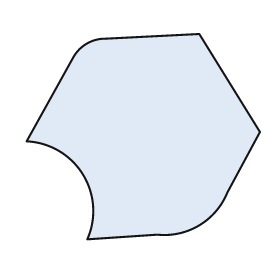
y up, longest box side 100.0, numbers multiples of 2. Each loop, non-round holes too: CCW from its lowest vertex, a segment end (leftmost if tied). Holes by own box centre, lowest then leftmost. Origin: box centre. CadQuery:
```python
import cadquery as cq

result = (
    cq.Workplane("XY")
    .moveTo(-24.0, -44.0)
    .lineTo(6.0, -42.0)
    .threePointArc((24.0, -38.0), (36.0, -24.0))
    .lineTo(50.0, 2.0)
    .lineTo(24.0, 44.0)
    .lineTo(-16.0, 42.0)
    .threePointArc((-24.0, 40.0), (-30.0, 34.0))
    .lineTo(-50.0, -2.0)
    .threePointArc((-26.0, -16.0), (-24.0, -44.0))
    .close()
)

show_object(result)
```